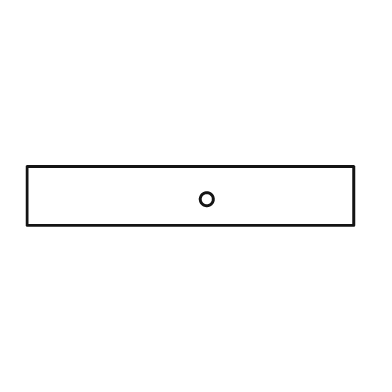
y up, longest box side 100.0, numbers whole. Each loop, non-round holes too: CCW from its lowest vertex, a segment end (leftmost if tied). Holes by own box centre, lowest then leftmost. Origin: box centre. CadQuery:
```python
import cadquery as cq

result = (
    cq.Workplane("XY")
    .moveTo(-50.0, -9.0)
    .lineTo(50.0, -9.0)
    .lineTo(50.0, 9.0)
    .lineTo(-50.0, 9.0)
    .close()
    .moveTo(5.0, -1.0)
    .circle(2.0)
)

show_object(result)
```